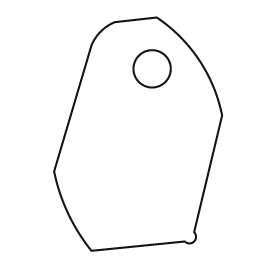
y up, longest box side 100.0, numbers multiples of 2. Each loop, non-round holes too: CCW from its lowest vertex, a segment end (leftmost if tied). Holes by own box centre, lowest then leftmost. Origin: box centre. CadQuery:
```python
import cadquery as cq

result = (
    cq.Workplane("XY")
    .moveTo(-20.0, -50.0)
    .lineTo(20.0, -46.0)
    .threePointArc((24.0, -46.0), (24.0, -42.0))
    .lineTo(36.0, 8.0)
    .threePointArc((26.0, 32.0), (8.0, 50.0))
    .lineTo(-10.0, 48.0)
    .threePointArc((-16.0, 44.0), (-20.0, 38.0))
    .lineTo(-36.0, -16.0)
    .threePointArc((-30.0, -34.0), (-20.0, -50.0))
    .close()
    .moveTo(6.0, 28.0)
    .circle(8.0)
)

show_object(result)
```